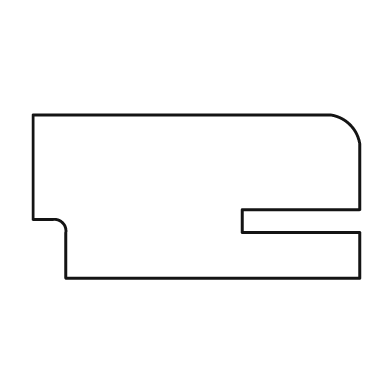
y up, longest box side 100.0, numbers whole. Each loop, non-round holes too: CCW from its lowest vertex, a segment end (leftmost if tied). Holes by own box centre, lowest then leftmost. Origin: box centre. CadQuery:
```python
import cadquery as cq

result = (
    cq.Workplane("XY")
    .moveTo(-40.0, -25.0)
    .lineTo(50.0, -25.0)
    .lineTo(50.0, -11.0)
    .lineTo(14.0, -11.0)
    .lineTo(14.0, -4.0)
    .lineTo(50.0, -4.0)
    .lineTo(50.0, 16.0)
    .threePointArc((47.0, 22.0), (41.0, 25.0))
    .lineTo(-50.0, 25.0)
    .lineTo(-50.0, -7.0)
    .lineTo(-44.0, -7.0)
    .threePointArc((-41.0, -8.0), (-40.0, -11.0))
    .close()
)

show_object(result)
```